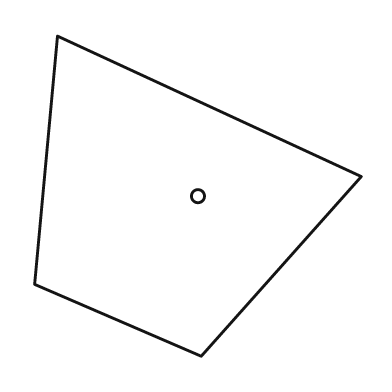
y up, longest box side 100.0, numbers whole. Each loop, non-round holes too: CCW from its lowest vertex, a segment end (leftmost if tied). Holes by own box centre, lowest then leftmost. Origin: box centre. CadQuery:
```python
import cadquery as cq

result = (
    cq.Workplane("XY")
    .moveTo(1.0, -49.0)
    .lineTo(50.0, 6.0)
    .lineTo(-43.0, 49.0)
    .lineTo(-50.0, -27.0)
    .close()
    .moveTo(0.0, 0.0)
    .circle(2.0)
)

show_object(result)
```